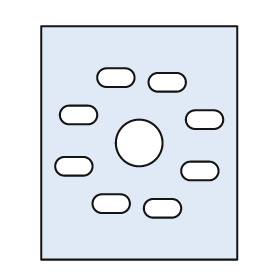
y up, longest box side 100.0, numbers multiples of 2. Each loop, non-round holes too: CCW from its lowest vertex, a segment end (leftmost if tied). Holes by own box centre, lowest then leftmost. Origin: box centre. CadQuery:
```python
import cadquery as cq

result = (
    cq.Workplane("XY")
    .moveTo(-42.0, -50.0)
    .lineTo(42.0, -50.0)
    .lineTo(42.0, 50.0)
    .lineTo(-42.0, 50.0)
    .close()
    .moveTo(6.0, -32.0)
    .lineTo(14.0, -32.0)
    .threePointArc((18.0, -28.0), (14.0, -24.0))
    .lineTo(6.0, -24.0)
    .threePointArc((2.0, -28.0), (6.0, -32.0))
    .close()
    .moveTo(-16.0, -30.0)
    .lineTo(-8.0, -30.0)
    .threePointArc((-4.0, -26.0), (-8.0, -22.0))
    .lineTo(-16.0, -22.0)
    .threePointArc((-20.0, -26.0), (-16.0, -30.0))
    .close()
    .moveTo(22.0, -16.0)
    .lineTo(30.0, -16.0)
    .threePointArc((34.0, -12.0), (30.0, -8.0))
    .lineTo(22.0, -8.0)
    .threePointArc((18.0, -12.0), (22.0, -16.0))
    .close()
    .moveTo(-32.0, -14.0)
    .lineTo(-24.0, -14.0)
    .threePointArc((-20.0, -10.0), (-24.0, -6.0))
    .lineTo(-32.0, -6.0)
    .threePointArc((-36.0, -10.0), (-32.0, -14.0))
    .close()
    .moveTo(0.0, 0.0)
    .circle(10.0)
    .moveTo(24.0, 6.0)
    .lineTo(32.0, 6.0)
    .threePointArc((36.0, 10.0), (32.0, 14.0))
    .lineTo(24.0, 14.0)
    .threePointArc((20.0, 10.0), (24.0, 6.0))
    .close()
    .moveTo(-30.0, 8.0)
    .lineTo(-22.0, 8.0)
    .threePointArc((-18.0, 12.0), (-22.0, 16.0))
    .lineTo(-30.0, 16.0)
    .threePointArc((-34.0, 12.0), (-30.0, 8.0))
    .close()
    .moveTo(8.0, 22.0)
    .lineTo(16.0, 22.0)
    .threePointArc((20.0, 26.0), (16.0, 30.0))
    .lineTo(8.0, 30.0)
    .threePointArc((4.0, 26.0), (8.0, 22.0))
    .close()
    .moveTo(-14.0, 24.0)
    .lineTo(-6.0, 24.0)
    .threePointArc((-2.0, 28.0), (-6.0, 32.0))
    .lineTo(-14.0, 32.0)
    .threePointArc((-18.0, 28.0), (-14.0, 24.0))
    .close()
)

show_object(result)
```